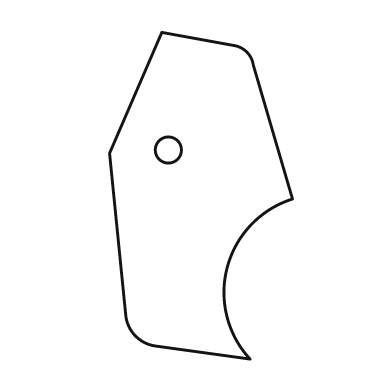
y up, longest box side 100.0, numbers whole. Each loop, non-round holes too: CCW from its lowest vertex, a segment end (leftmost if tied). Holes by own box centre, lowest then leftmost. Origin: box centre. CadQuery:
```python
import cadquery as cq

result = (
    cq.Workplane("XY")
    .moveTo(15.0, -50.0)
    .threePointArc((8.0, -22.0), (28.0, -1.0))
    .lineTo(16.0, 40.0)
    .threePointArc((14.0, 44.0), (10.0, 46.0))
    .lineTo(-12.0, 50.0)
    .lineTo(-28.0, 13.0)
    .lineTo(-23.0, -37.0)
    .threePointArc((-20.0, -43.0), (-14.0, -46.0))
    .close()
    .moveTo(-10.0, 14.0)
    .circle(4.0)
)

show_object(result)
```